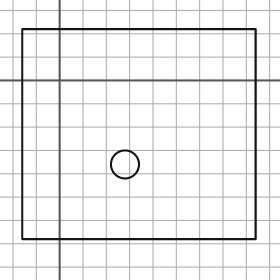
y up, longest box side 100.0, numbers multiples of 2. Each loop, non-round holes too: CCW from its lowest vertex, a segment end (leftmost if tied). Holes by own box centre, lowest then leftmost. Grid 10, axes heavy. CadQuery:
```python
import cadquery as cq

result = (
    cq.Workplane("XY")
    .moveTo(-16.0, -68.0)
    .lineTo(84.0, -68.0)
    .lineTo(84.0, 22.0)
    .lineTo(-16.0, 22.0)
    .close()
    .moveTo(28.0, -36.0)
    .circle(6.0)
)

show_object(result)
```